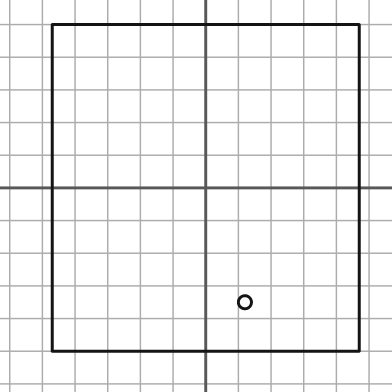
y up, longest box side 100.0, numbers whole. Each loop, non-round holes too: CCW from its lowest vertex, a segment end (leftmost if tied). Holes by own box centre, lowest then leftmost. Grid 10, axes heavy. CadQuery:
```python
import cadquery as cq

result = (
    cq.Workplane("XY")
    .moveTo(-47.0, -50.0)
    .lineTo(47.0, -50.0)
    .lineTo(47.0, 50.0)
    .lineTo(-47.0, 50.0)
    .close()
    .moveTo(12.0, -35.0)
    .circle(2.0)
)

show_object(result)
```